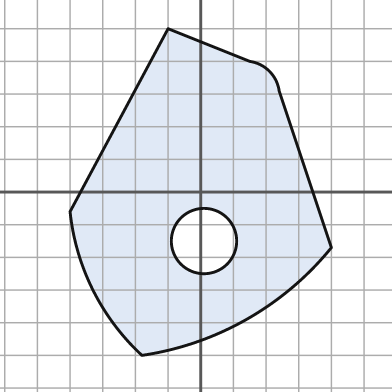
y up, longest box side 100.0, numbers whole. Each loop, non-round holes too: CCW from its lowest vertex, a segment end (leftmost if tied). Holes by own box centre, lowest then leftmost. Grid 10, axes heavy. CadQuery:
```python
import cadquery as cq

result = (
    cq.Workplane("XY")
    .moveTo(-18.0, -50.0)
    .threePointArc((14.0, -39.0), (40.0, -17.0))
    .lineTo(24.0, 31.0)
    .threePointArc((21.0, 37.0), (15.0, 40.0))
    .lineTo(-10.0, 50.0)
    .lineTo(-40.0, -6.0)
    .threePointArc((-33.0, -30.0), (-18.0, -50.0))
    .close()
    .moveTo(1.0, -15.0)
    .circle(10.0)
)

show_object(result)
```